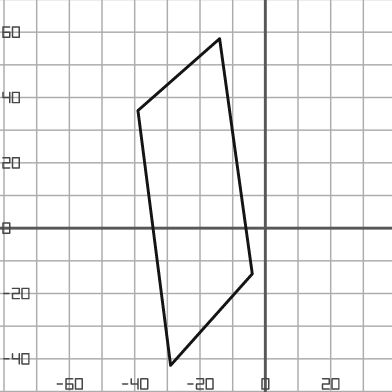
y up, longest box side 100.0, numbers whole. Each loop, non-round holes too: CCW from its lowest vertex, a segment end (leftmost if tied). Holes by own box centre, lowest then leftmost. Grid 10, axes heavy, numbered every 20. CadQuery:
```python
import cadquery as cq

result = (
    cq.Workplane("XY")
    .moveTo(-29.0, -42.0)
    .lineTo(-4.0, -14.0)
    .lineTo(-14.0, 58.0)
    .lineTo(-39.0, 36.0)
    .close()
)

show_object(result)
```